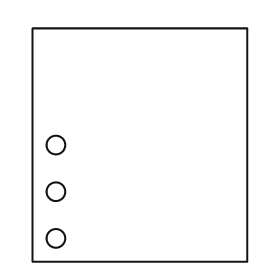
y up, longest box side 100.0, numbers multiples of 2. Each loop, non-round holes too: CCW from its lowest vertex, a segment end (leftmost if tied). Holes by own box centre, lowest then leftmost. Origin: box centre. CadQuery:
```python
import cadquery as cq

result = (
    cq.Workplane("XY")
    .moveTo(-46.0, -50.0)
    .lineTo(46.0, -50.0)
    .lineTo(46.0, 50.0)
    .lineTo(-46.0, 50.0)
    .close()
    .moveTo(-36.0, -40.0)
    .circle(4.0)
    .moveTo(-36.0, -20.0)
    .circle(4.0)
    .moveTo(-36.0, 0.0)
    .circle(4.0)
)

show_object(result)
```